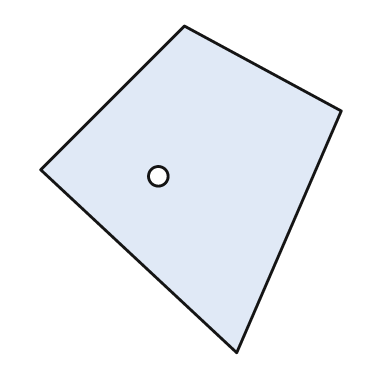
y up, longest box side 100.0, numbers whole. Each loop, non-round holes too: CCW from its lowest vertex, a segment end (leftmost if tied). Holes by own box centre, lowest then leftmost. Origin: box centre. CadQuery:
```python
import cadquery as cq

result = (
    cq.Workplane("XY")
    .moveTo(14.0, -50.0)
    .lineTo(46.0, 24.0)
    .lineTo(-2.0, 50.0)
    .lineTo(-46.0, 6.0)
    .close()
    .moveTo(-10.0, 4.0)
    .circle(3.0)
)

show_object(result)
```